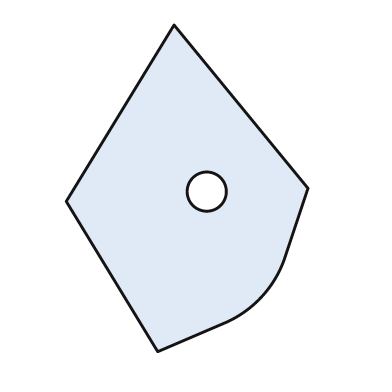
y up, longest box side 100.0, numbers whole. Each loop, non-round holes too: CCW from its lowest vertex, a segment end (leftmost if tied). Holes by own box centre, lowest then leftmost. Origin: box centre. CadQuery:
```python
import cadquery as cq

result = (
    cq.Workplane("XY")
    .moveTo(-9.0, -50.0)
    .lineTo(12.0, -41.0)
    .threePointArc((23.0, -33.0), (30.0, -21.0))
    .lineTo(37.0, 0.0)
    .lineTo(-4.0, 50.0)
    .lineTo(-37.0, -4.0)
    .close()
    .moveTo(6.0, -1.0)
    .circle(6.0)
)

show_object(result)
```